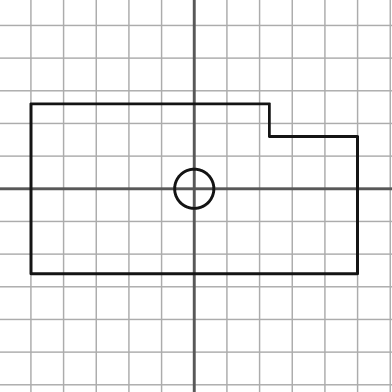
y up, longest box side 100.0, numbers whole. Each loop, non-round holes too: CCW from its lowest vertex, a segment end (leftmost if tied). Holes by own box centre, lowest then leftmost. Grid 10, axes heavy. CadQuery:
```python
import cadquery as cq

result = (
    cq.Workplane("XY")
    .moveTo(-50.0, -26.0)
    .lineTo(50.0, -26.0)
    .lineTo(50.0, 16.0)
    .lineTo(23.0, 16.0)
    .lineTo(23.0, 26.0)
    .lineTo(-50.0, 26.0)
    .close()
    .moveTo(0.0, 0.0)
    .circle(6.0)
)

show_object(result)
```